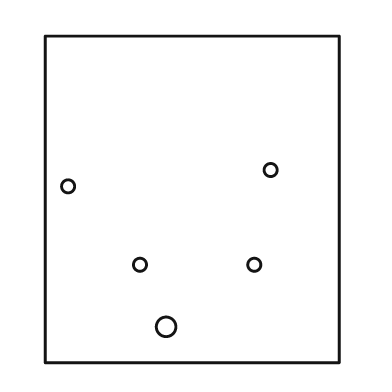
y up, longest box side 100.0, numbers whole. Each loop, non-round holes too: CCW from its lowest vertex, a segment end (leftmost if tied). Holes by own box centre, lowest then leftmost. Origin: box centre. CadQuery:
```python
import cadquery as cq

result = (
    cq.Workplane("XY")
    .moveTo(-45.0, -50.0)
    .lineTo(45.0, -50.0)
    .lineTo(45.0, 50.0)
    .lineTo(-45.0, 50.0)
    .close()
    .moveTo(-8.0, -39.0)
    .circle(3.0)
    .moveTo(-16.0, -20.0)
    .circle(2.0)
    .moveTo(19.0, -20.0)
    .circle(2.0)
    .moveTo(-38.0, 4.0)
    .circle(2.0)
    .moveTo(24.0, 9.0)
    .circle(2.0)
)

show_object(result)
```